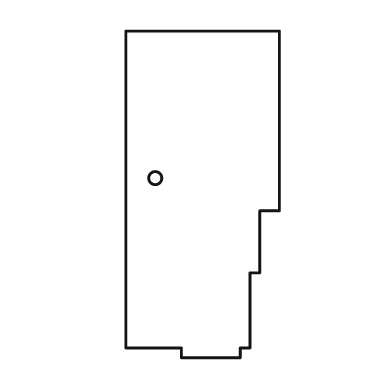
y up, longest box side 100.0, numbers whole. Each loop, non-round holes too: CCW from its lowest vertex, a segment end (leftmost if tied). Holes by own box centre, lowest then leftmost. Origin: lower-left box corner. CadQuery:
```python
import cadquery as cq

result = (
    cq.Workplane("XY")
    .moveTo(17.0, 0.0)
    .lineTo(35.0, 0.0)
    .lineTo(35.0, 3.0)
    .lineTo(38.0, 3.0)
    .lineTo(38.0, 26.0)
    .lineTo(41.0, 26.0)
    .lineTo(41.0, 45.0)
    .lineTo(47.0, 45.0)
    .lineTo(47.0, 100.0)
    .lineTo(0.0, 100.0)
    .lineTo(0.0, 3.0)
    .lineTo(17.0, 3.0)
    .close()
    .moveTo(9.0, 55.0)
    .circle(2.0)
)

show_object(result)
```